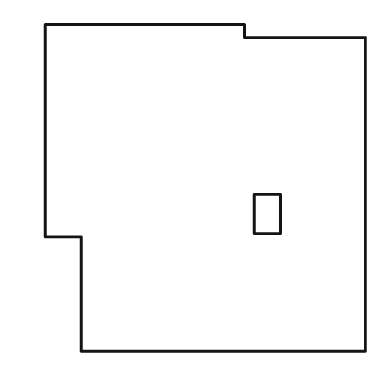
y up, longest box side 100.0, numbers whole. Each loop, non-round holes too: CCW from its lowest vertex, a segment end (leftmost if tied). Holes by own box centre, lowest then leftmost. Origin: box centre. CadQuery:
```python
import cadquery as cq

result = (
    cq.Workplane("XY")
    .moveTo(-38.0, -50.0)
    .lineTo(49.0, -50.0)
    .lineTo(49.0, 46.0)
    .lineTo(12.0, 46.0)
    .lineTo(12.0, 50.0)
    .lineTo(-49.0, 50.0)
    .lineTo(-49.0, -15.0)
    .lineTo(-38.0, -15.0)
    .close()
    .moveTo(15.0, -14.0)
    .lineTo(23.0, -14.0)
    .lineTo(23.0, -2.0)
    .lineTo(15.0, -2.0)
    .close()
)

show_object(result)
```